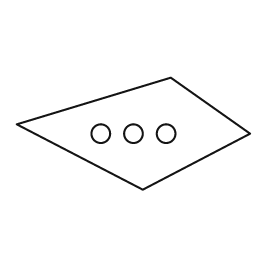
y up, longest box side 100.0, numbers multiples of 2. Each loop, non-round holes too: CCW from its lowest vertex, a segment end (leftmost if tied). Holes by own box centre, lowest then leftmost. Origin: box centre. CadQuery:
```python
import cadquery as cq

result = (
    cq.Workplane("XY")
    .moveTo(4.0, -24.0)
    .lineTo(50.0, 0.0)
    .lineTo(16.0, 24.0)
    .lineTo(-50.0, 4.0)
    .close()
    .moveTo(-14.0, 0.0)
    .circle(4.0)
    .moveTo(0.0, 0.0)
    .circle(4.0)
    .moveTo(14.0, 0.0)
    .circle(4.0)
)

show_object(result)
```